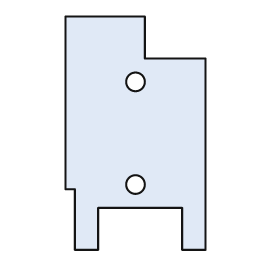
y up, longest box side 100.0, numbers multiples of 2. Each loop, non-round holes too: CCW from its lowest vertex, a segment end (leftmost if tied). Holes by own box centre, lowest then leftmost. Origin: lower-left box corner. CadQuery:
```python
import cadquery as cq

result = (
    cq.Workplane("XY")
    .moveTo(4.0, 0.0)
    .lineTo(14.0, 0.0)
    .lineTo(14.0, 18.0)
    .lineTo(50.0, 18.0)
    .lineTo(50.0, 0.0)
    .lineTo(60.0, 0.0)
    .lineTo(60.0, 82.0)
    .lineTo(34.0, 82.0)
    .lineTo(34.0, 100.0)
    .lineTo(0.0, 100.0)
    .lineTo(0.0, 26.0)
    .lineTo(4.0, 26.0)
    .close()
    .moveTo(30.0, 28.0)
    .circle(4.0)
    .moveTo(30.0, 72.0)
    .circle(4.0)
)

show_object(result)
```